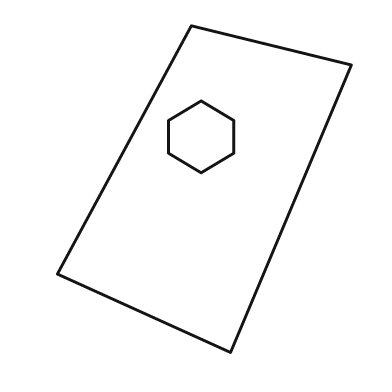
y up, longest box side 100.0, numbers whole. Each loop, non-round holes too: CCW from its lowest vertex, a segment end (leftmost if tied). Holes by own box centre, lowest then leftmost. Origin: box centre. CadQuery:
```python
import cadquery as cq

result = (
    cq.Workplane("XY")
    .moveTo(8.0, -50.0)
    .lineTo(45.0, 38.0)
    .lineTo(-4.0, 50.0)
    .lineTo(-45.0, -26.0)
    .close()
    .moveTo(-1.0, 5.0)
    .lineTo(9.0, 11.0)
    .lineTo(9.0, 21.0)
    .lineTo(-1.0, 27.0)
    .lineTo(-11.0, 21.0)
    .lineTo(-11.0, 11.0)
    .close()
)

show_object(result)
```